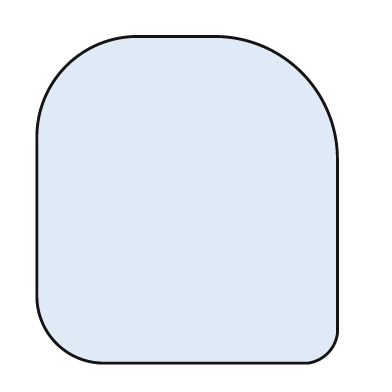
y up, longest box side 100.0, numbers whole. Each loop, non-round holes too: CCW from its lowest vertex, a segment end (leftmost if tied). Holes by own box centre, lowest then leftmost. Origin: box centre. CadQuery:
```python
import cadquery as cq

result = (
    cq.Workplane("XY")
    .moveTo(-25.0, -50.0)
    .lineTo(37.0, -50.0)
    .threePointArc((43.0, -47.0), (46.0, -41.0))
    .lineTo(46.0, 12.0)
    .threePointArc((35.0, 39.0), (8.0, 50.0))
    .lineTo(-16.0, 50.0)
    .threePointArc((-37.0, 41.0), (-46.0, 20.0))
    .lineTo(-46.0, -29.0)
    .threePointArc((-40.0, -44.0), (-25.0, -50.0))
    .close()
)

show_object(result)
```